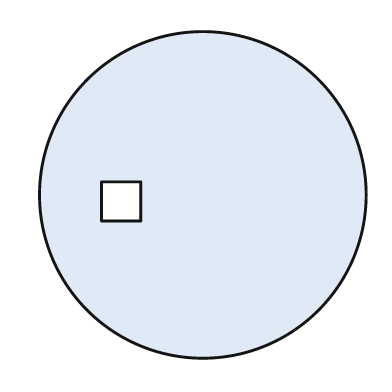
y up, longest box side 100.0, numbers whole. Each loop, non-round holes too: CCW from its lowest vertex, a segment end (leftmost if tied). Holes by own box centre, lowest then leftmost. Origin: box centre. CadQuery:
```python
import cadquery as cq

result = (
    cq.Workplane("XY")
    .moveTo(0.0, 0.0)
    .circle(50.0)
    .moveTo(-31.0, -8.0)
    .lineTo(-19.0, -8.0)
    .lineTo(-19.0, 4.0)
    .lineTo(-31.0, 4.0)
    .close()
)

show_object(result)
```